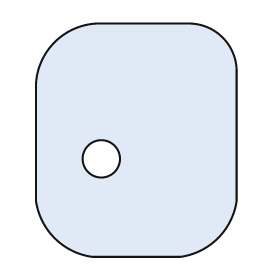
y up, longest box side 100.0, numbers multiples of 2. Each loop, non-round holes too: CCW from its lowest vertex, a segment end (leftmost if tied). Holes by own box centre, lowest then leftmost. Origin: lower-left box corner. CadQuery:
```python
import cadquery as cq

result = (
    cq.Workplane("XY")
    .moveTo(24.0, 0.0)
    .lineTo(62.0, 0.0)
    .threePointArc((78.0, 8.0), (86.0, 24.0))
    .lineTo(86.0, 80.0)
    .threePointArc((80.0, 94.0), (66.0, 100.0))
    .lineTo(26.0, 100.0)
    .threePointArc((8.0, 92.0), (0.0, 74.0))
    .lineTo(0.0, 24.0)
    .threePointArc((8.0, 8.0), (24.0, 0.0))
    .close()
    .moveTo(28.0, 42.0)
    .circle(8.0)
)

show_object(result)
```